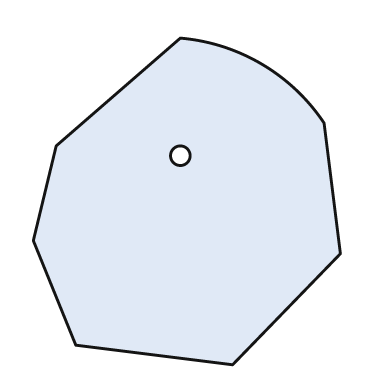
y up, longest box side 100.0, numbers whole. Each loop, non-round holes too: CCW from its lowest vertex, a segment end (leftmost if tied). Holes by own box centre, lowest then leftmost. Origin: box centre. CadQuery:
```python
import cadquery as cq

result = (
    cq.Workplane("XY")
    .moveTo(14.0, -50.0)
    .lineTo(47.0, -16.0)
    .lineTo(42.0, 24.0)
    .threePointArc((23.0, 42.0), (-2.0, 50.0))
    .lineTo(-40.0, 17.0)
    .lineTo(-47.0, -12.0)
    .lineTo(-34.0, -44.0)
    .close()
    .moveTo(-2.0, 14.0)
    .circle(3.0)
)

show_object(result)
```